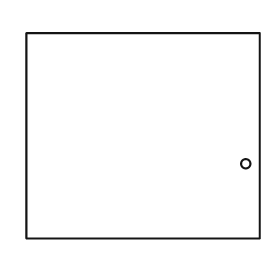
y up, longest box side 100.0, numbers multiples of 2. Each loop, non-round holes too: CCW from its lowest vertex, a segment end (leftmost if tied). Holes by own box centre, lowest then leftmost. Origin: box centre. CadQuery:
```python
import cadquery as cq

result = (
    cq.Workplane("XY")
    .moveTo(-50.0, -44.0)
    .lineTo(50.0, -44.0)
    .lineTo(50.0, 44.0)
    .lineTo(-50.0, 44.0)
    .close()
    .moveTo(44.0, -12.0)
    .circle(2.0)
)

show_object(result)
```